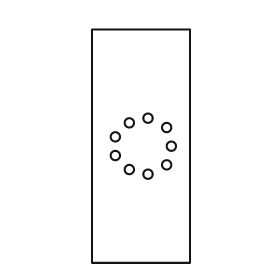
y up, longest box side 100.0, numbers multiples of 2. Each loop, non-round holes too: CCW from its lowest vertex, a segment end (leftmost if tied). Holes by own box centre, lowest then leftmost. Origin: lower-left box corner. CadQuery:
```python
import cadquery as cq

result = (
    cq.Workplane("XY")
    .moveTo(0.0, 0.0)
    .lineTo(42.0, 0.0)
    .lineTo(42.0, 100.0)
    .lineTo(0.0, 100.0)
    .close()
    .moveTo(24.0, 38.0)
    .circle(2.0)
    .moveTo(16.0, 40.0)
    .circle(2.0)
    .moveTo(32.0, 42.0)
    .circle(2.0)
    .moveTo(10.0, 46.0)
    .circle(2.0)
    .moveTo(34.0, 50.0)
    .circle(2.0)
    .moveTo(10.0, 54.0)
    .circle(2.0)
    .moveTo(32.0, 58.0)
    .circle(2.0)
    .moveTo(16.0, 60.0)
    .circle(2.0)
    .moveTo(24.0, 62.0)
    .circle(2.0)
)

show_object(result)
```